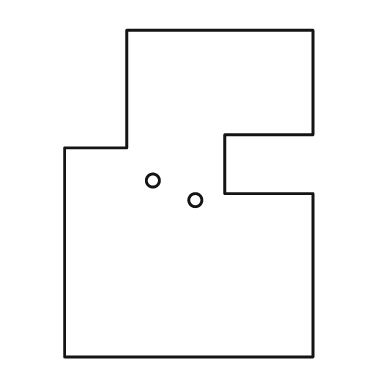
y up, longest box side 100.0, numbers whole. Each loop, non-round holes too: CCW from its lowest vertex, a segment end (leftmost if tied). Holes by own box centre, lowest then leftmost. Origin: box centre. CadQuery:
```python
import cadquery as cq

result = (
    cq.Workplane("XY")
    .moveTo(-38.0, -50.0)
    .lineTo(38.0, -50.0)
    .lineTo(38.0, 0.0)
    .lineTo(11.0, 0.0)
    .lineTo(11.0, 18.0)
    .lineTo(38.0, 18.0)
    .lineTo(38.0, 50.0)
    .lineTo(-19.0, 50.0)
    .lineTo(-19.0, 14.0)
    .lineTo(-38.0, 14.0)
    .close()
    .moveTo(2.0, -2.0)
    .circle(2.0)
    .moveTo(-11.0, 4.0)
    .circle(2.0)
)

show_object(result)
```